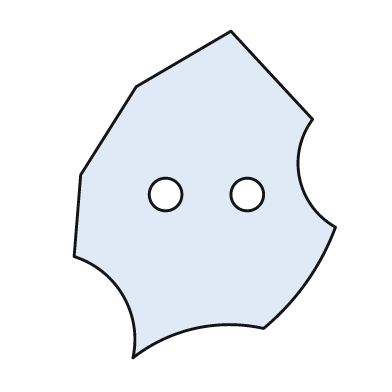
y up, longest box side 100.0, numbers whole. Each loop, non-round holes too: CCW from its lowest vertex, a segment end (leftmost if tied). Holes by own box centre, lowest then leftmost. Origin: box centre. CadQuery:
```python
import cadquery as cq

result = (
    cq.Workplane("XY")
    .moveTo(-22.0, -50.0)
    .threePointArc((-3.0, -41.0), (18.0, -41.0))
    .threePointArc((31.0, -27.0), (40.0, -10.0))
    .threePointArc((29.0, 5.0), (33.0, 23.0))
    .lineTo(8.0, 50.0)
    .lineTo(-21.0, 33.0)
    .lineTo(-38.0, 6.0)
    .lineTo(-40.0, -19.0)
    .threePointArc((-25.0, -31.0), (-22.0, -50.0))
    .close()
    .moveTo(-12.0, 0.0)
    .circle(5.0)
    .moveTo(13.0, 0.0)
    .circle(5.0)
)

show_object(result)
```